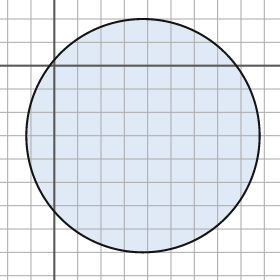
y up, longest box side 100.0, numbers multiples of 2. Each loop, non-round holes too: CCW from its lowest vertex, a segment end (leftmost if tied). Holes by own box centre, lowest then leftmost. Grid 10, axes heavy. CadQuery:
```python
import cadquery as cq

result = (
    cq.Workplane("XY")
    .moveTo(38.0, -30.0)
    .circle(50.0)
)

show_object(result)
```